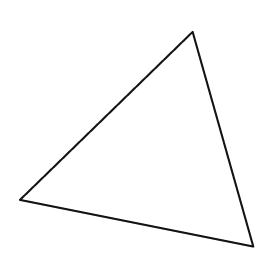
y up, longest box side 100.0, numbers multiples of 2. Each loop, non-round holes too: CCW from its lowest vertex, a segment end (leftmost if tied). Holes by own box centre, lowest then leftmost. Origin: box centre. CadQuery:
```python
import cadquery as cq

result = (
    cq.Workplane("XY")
    .moveTo(50.0, -46.0)
    .lineTo(24.0, 46.0)
    .lineTo(-50.0, -26.0)
    .close()
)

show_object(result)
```